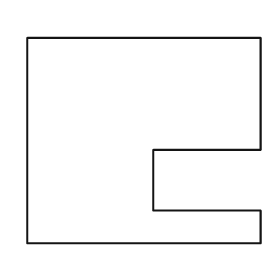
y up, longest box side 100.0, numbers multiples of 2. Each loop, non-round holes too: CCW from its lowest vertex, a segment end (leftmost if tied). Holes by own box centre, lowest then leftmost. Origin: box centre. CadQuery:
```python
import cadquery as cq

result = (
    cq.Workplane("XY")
    .moveTo(-50.0, -44.0)
    .lineTo(50.0, -44.0)
    .lineTo(50.0, -30.0)
    .lineTo(4.0, -30.0)
    .lineTo(4.0, -4.0)
    .lineTo(50.0, -4.0)
    .lineTo(50.0, 44.0)
    .lineTo(-50.0, 44.0)
    .close()
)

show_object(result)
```